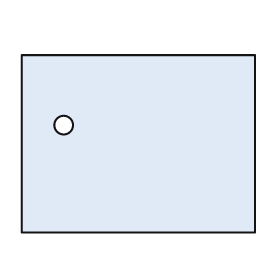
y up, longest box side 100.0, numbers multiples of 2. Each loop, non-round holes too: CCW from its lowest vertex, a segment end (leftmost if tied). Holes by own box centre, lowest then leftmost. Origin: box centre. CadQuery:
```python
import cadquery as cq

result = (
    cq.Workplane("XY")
    .moveTo(-50.0, -38.0)
    .lineTo(50.0, -38.0)
    .lineTo(50.0, 38.0)
    .lineTo(-50.0, 38.0)
    .close()
    .moveTo(-32.0, 8.0)
    .circle(4.0)
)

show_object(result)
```